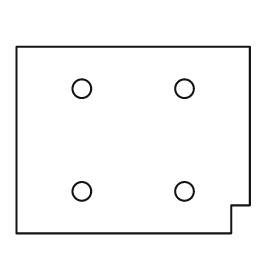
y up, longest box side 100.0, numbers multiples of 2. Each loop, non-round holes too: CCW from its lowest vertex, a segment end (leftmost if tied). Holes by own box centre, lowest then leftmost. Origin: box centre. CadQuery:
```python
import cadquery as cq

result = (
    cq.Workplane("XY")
    .moveTo(-50.0, -40.0)
    .lineTo(42.0, -40.0)
    .lineTo(42.0, -28.0)
    .lineTo(50.0, -28.0)
    .lineTo(50.0, 40.0)
    .lineTo(-50.0, 40.0)
    .close()
    .moveTo(-22.0, -22.0)
    .circle(4.0)
    .moveTo(22.0, -22.0)
    .circle(4.0)
    .moveTo(-22.0, 22.0)
    .circle(4.0)
    .moveTo(22.0, 22.0)
    .circle(4.0)
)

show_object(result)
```